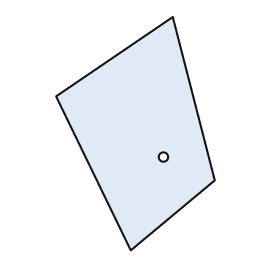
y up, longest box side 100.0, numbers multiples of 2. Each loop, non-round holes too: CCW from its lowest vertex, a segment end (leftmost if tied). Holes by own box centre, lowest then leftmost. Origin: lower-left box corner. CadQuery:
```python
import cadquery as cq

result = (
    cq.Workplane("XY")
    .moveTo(32.0, 0.0)
    .lineTo(68.0, 30.0)
    .lineTo(50.0, 100.0)
    .lineTo(0.0, 66.0)
    .close()
    .moveTo(46.0, 40.0)
    .circle(2.0)
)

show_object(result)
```